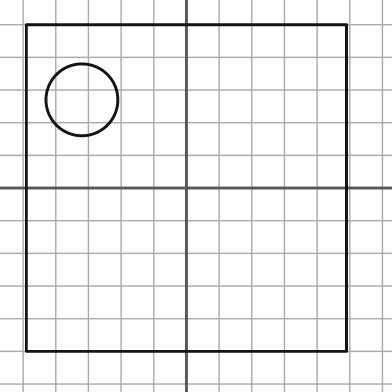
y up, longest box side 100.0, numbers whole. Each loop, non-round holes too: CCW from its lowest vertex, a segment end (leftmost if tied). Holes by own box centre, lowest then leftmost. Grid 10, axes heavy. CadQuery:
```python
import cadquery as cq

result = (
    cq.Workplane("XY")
    .moveTo(-49.0, -50.0)
    .lineTo(49.0, -50.0)
    .lineTo(49.0, 50.0)
    .lineTo(-49.0, 50.0)
    .close()
    .moveTo(-32.0, 27.0)
    .circle(11.0)
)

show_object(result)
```